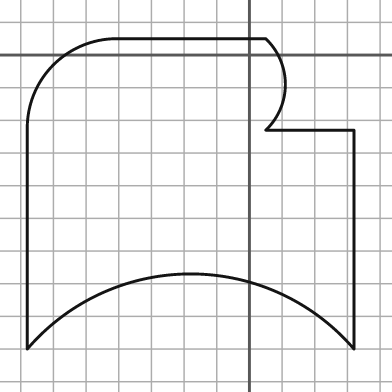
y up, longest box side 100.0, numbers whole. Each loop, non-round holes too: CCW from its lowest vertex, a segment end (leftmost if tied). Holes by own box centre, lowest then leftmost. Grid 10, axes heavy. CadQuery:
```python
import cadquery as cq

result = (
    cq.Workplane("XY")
    .moveTo(-68.0, -90.0)
    .threePointArc((-18.0, -67.0), (32.0, -90.0))
    .lineTo(32.0, -23.0)
    .lineTo(5.0, -23.0)
    .threePointArc((11.0, -9.0), (5.0, 5.0))
    .lineTo(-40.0, 5.0)
    .threePointArc((-60.0, -3.0), (-68.0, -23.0))
    .close()
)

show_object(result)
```